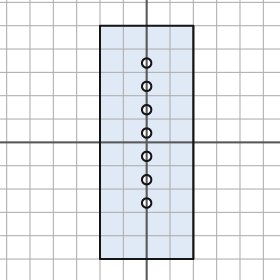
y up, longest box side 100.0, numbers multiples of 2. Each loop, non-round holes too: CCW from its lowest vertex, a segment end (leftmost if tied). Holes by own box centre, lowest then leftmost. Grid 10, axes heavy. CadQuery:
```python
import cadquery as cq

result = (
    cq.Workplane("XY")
    .moveTo(-20.0, -50.0)
    .lineTo(20.0, -50.0)
    .lineTo(20.0, 50.0)
    .lineTo(-20.0, 50.0)
    .close()
    .moveTo(0.0, -26.0)
    .circle(2.0)
    .moveTo(0.0, -16.0)
    .circle(2.0)
    .moveTo(0.0, -6.0)
    .circle(2.0)
    .moveTo(0.0, 4.0)
    .circle(2.0)
    .moveTo(0.0, 14.0)
    .circle(2.0)
    .moveTo(0.0, 24.0)
    .circle(2.0)
    .moveTo(0.0, 34.0)
    .circle(2.0)
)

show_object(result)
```